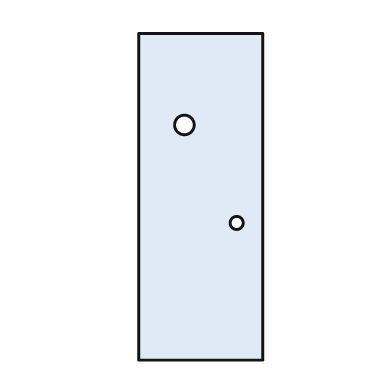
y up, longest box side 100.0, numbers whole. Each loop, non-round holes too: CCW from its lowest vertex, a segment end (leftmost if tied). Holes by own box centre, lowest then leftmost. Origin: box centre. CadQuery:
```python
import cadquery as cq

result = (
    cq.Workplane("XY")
    .moveTo(-19.0, -50.0)
    .lineTo(19.0, -50.0)
    .lineTo(19.0, 50.0)
    .lineTo(-19.0, 50.0)
    .close()
    .moveTo(11.0, -8.0)
    .circle(2.0)
    .moveTo(-5.0, 22.0)
    .circle(3.0)
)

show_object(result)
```